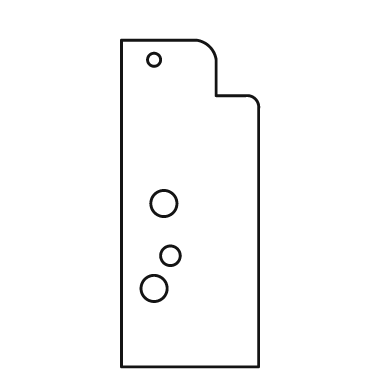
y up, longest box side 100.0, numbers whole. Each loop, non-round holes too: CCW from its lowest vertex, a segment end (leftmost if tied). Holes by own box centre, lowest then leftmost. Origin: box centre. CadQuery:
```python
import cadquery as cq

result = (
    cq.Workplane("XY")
    .moveTo(-21.0, -50.0)
    .lineTo(21.0, -50.0)
    .lineTo(21.0, 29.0)
    .threePointArc((20.0, 32.0), (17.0, 33.0))
    .lineTo(8.0, 33.0)
    .lineTo(8.0, 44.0)
    .threePointArc((6.0, 48.0), (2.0, 50.0))
    .lineTo(-21.0, 50.0)
    .close()
    .moveTo(-11.0, -26.0)
    .circle(4.0)
    .moveTo(-6.0, -16.0)
    .circle(3.0)
    .moveTo(-8.0, 0.0)
    .circle(4.0)
    .moveTo(-11.0, 44.0)
    .circle(2.0)
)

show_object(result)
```